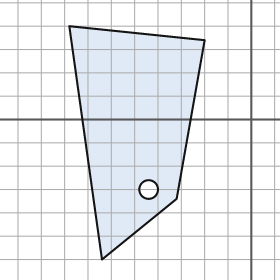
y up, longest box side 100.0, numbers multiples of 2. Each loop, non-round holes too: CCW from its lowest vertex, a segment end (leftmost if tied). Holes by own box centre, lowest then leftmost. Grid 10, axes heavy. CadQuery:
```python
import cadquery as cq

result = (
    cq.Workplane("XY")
    .moveTo(-64.0, -60.0)
    .lineTo(-32.0, -34.0)
    .lineTo(-20.0, 34.0)
    .lineTo(-78.0, 40.0)
    .close()
    .moveTo(-44.0, -30.0)
    .circle(4.0)
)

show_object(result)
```